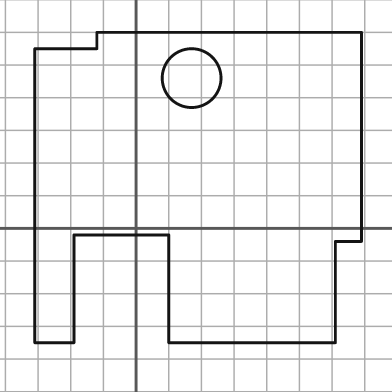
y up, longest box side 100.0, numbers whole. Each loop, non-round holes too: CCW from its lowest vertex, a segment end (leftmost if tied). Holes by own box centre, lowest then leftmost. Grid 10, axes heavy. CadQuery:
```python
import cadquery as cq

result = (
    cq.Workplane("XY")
    .moveTo(-31.0, -35.0)
    .lineTo(-19.0, -35.0)
    .lineTo(-19.0, -2.0)
    .lineTo(10.0, -2.0)
    .lineTo(10.0, -35.0)
    .lineTo(61.0, -35.0)
    .lineTo(61.0, -4.0)
    .lineTo(69.0, -4.0)
    .lineTo(69.0, 60.0)
    .lineTo(-12.0, 60.0)
    .lineTo(-12.0, 55.0)
    .lineTo(-31.0, 55.0)
    .close()
    .moveTo(17.0, 46.0)
    .circle(9.0)
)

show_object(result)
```